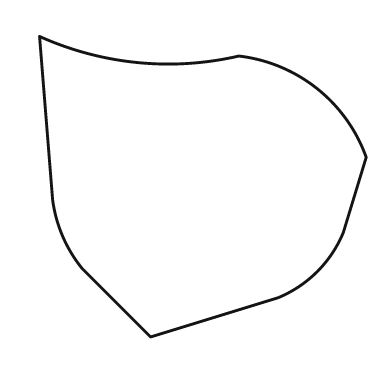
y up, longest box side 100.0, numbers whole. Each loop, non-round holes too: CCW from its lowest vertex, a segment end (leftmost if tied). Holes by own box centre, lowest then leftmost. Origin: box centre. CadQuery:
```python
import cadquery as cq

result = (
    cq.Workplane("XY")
    .moveTo(-16.0, -46.0)
    .lineTo(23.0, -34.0)
    .threePointArc((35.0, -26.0), (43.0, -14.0))
    .lineTo(50.0, 9.0)
    .threePointArc((35.0, 30.0), (11.0, 40.0))
    .threePointArc((-20.0, 38.0), (-50.0, 46.0))
    .lineTo(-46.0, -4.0)
    .threePointArc((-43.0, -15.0), (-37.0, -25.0))
    .close()
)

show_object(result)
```